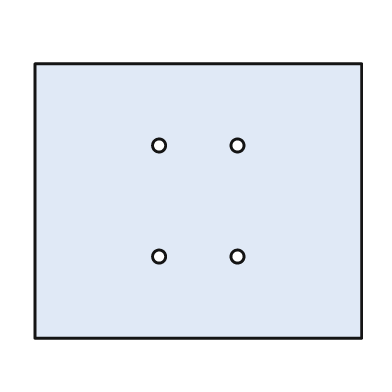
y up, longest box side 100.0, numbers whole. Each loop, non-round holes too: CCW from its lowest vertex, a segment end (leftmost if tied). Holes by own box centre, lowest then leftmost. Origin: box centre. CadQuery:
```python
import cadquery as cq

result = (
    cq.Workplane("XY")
    .moveTo(-50.0, -42.0)
    .lineTo(50.0, -42.0)
    .lineTo(50.0, 42.0)
    .lineTo(-50.0, 42.0)
    .close()
    .moveTo(-12.0, -17.0)
    .circle(2.0)
    .moveTo(12.0, -17.0)
    .circle(2.0)
    .moveTo(-12.0, 17.0)
    .circle(2.0)
    .moveTo(12.0, 17.0)
    .circle(2.0)
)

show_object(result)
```